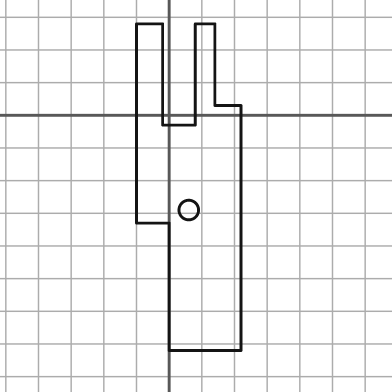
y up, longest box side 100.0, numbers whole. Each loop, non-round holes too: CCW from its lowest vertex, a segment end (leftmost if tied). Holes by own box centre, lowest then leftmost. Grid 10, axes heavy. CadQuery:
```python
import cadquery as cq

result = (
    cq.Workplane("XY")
    .moveTo(0.0, -72.0)
    .lineTo(22.0, -72.0)
    .lineTo(22.0, 3.0)
    .lineTo(14.0, 3.0)
    .lineTo(14.0, 28.0)
    .lineTo(8.0, 28.0)
    .lineTo(8.0, -3.0)
    .lineTo(-2.0, -3.0)
    .lineTo(-2.0, 28.0)
    .lineTo(-10.0, 28.0)
    .lineTo(-10.0, -33.0)
    .lineTo(0.0, -33.0)
    .close()
    .moveTo(6.0, -29.0)
    .circle(3.0)
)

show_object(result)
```